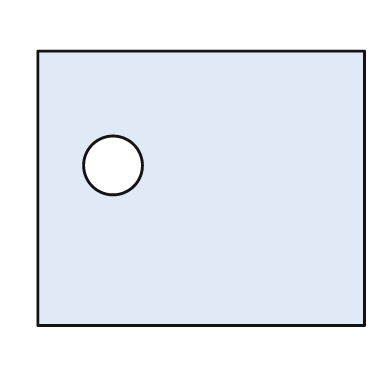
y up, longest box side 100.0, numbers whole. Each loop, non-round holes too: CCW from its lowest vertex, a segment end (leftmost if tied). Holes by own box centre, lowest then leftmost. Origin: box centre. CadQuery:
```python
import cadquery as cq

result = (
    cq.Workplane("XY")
    .moveTo(-50.0, -42.0)
    .lineTo(50.0, -42.0)
    .lineTo(50.0, 42.0)
    .lineTo(-50.0, 42.0)
    .close()
    .moveTo(-27.0, 7.0)
    .circle(9.0)
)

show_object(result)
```